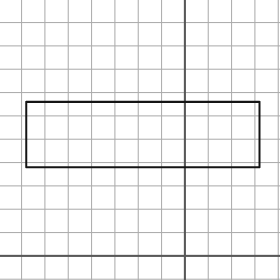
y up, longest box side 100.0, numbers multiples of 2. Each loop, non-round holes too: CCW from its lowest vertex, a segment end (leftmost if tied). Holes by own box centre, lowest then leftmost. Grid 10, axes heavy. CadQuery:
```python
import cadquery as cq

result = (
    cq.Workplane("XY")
    .moveTo(-68.0, 38.0)
    .lineTo(32.0, 38.0)
    .lineTo(32.0, 66.0)
    .lineTo(-68.0, 66.0)
    .close()
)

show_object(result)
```